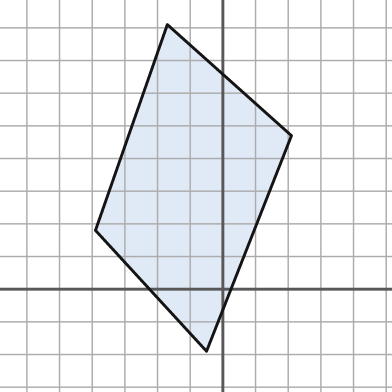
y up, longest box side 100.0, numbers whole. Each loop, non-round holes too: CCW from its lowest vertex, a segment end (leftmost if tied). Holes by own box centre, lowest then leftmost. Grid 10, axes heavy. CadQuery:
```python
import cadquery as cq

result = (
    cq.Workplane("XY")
    .moveTo(-5.0, -19.0)
    .lineTo(21.0, 47.0)
    .lineTo(-17.0, 81.0)
    .lineTo(-39.0, 18.0)
    .close()
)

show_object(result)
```